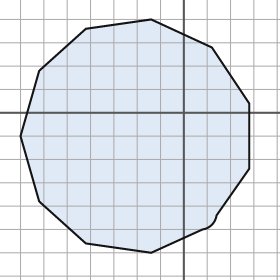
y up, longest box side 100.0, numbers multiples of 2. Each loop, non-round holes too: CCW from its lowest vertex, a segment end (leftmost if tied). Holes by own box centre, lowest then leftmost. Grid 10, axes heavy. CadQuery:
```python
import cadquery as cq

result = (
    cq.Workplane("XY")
    .moveTo(-14.0, -60.0)
    .lineTo(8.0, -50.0)
    .threePointArc((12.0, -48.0), (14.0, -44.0))
    .lineTo(28.0, -24.0)
    .lineTo(28.0, 4.0)
    .lineTo(12.0, 28.0)
    .lineTo(-14.0, 40.0)
    .lineTo(-42.0, 36.0)
    .lineTo(-62.0, 18.0)
    .lineTo(-70.0, -10.0)
    .lineTo(-62.0, -38.0)
    .lineTo(-42.0, -56.0)
    .close()
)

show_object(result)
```